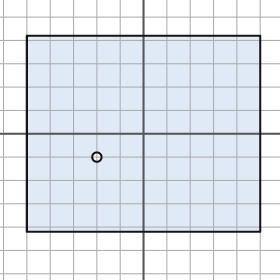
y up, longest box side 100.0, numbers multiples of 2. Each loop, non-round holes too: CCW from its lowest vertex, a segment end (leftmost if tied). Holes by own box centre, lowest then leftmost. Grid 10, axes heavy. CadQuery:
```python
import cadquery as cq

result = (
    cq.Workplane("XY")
    .moveTo(-50.0, -42.0)
    .lineTo(50.0, -42.0)
    .lineTo(50.0, 42.0)
    .lineTo(-50.0, 42.0)
    .close()
    .moveTo(-20.0, -10.0)
    .circle(2.0)
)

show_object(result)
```